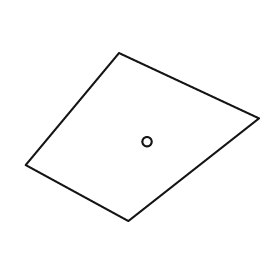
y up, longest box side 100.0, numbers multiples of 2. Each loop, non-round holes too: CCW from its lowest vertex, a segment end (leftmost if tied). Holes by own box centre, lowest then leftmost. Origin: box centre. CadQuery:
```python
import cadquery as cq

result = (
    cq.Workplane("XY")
    .moveTo(-6.0, -36.0)
    .lineTo(50.0, 8.0)
    .lineTo(-10.0, 36.0)
    .lineTo(-50.0, -12.0)
    .close()
    .moveTo(2.0, -2.0)
    .circle(2.0)
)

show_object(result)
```